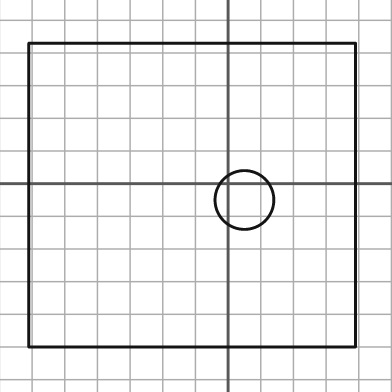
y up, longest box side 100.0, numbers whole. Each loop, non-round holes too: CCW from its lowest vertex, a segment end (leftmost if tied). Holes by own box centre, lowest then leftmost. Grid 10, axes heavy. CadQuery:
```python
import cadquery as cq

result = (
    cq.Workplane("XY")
    .moveTo(-61.0, -50.0)
    .lineTo(39.0, -50.0)
    .lineTo(39.0, 43.0)
    .lineTo(-61.0, 43.0)
    .close()
    .moveTo(5.0, -5.0)
    .circle(9.0)
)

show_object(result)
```